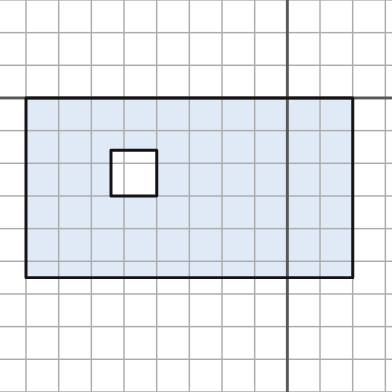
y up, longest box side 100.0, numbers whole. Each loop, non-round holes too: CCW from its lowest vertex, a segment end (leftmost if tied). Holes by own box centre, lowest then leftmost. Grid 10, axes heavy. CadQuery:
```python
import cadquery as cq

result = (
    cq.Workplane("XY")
    .moveTo(-80.0, -55.0)
    .lineTo(20.0, -55.0)
    .lineTo(20.0, 0.0)
    .lineTo(-80.0, 0.0)
    .close()
    .moveTo(-54.0, -30.0)
    .lineTo(-40.0, -30.0)
    .lineTo(-40.0, -16.0)
    .lineTo(-54.0, -16.0)
    .close()
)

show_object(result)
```